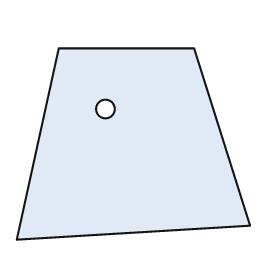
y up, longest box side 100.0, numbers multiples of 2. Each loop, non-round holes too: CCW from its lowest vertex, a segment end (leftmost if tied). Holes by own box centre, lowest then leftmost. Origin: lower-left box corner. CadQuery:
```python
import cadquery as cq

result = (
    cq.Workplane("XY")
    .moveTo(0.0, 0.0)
    .lineTo(100.0, 6.0)
    .lineTo(76.0, 82.0)
    .lineTo(18.0, 82.0)
    .close()
    .moveTo(38.0, 56.0)
    .circle(4.0)
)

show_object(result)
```